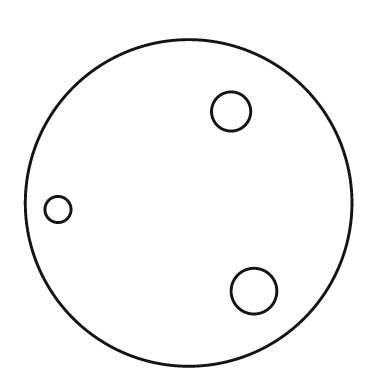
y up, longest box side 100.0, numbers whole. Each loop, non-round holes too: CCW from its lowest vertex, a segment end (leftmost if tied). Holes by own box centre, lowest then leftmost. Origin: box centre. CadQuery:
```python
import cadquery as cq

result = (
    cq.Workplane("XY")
    .moveTo(0.0, 0.0)
    .circle(50.0)
    .moveTo(20.0, -27.0)
    .circle(7.0)
    .moveTo(-40.0, -2.0)
    .circle(4.0)
    .moveTo(13.0, 28.0)
    .circle(6.0)
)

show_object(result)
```